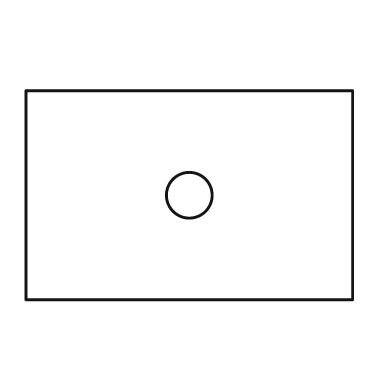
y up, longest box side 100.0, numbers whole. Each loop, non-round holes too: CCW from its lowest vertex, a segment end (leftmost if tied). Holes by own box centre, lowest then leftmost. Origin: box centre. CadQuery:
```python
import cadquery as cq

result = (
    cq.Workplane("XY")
    .moveTo(-50.0, -32.0)
    .lineTo(50.0, -32.0)
    .lineTo(50.0, 32.0)
    .lineTo(-50.0, 32.0)
    .close()
    .moveTo(0.0, 0.0)
    .circle(7.0)
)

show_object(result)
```